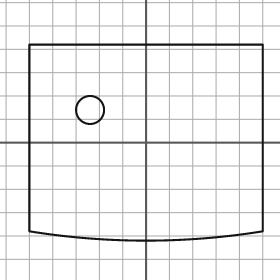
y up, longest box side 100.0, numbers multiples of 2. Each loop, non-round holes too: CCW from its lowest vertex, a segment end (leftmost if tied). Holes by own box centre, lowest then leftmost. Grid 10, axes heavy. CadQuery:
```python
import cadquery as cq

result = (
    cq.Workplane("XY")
    .moveTo(-50.0, -38.0)
    .threePointArc((0.0, -42.0), (50.0, -38.0))
    .lineTo(50.0, 42.0)
    .lineTo(-50.0, 42.0)
    .close()
    .moveTo(-24.0, 14.0)
    .circle(6.0)
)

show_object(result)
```